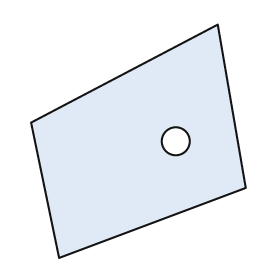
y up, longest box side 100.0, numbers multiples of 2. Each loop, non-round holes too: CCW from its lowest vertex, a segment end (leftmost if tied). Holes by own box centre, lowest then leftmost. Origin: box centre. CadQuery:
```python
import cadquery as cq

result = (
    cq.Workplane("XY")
    .moveTo(-34.0, -50.0)
    .lineTo(46.0, -20.0)
    .lineTo(34.0, 50.0)
    .lineTo(-46.0, 8.0)
    .close()
    .moveTo(16.0, 0.0)
    .circle(6.0)
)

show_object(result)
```